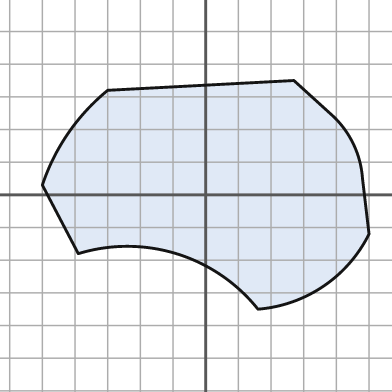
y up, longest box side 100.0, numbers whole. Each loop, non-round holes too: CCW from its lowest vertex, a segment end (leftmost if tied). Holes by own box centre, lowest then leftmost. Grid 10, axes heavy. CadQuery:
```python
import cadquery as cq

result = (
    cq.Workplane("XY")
    .moveTo(16.0, -35.0)
    .threePointArc((36.0, -28.0), (50.0, -12.0))
    .lineTo(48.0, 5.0)
    .threePointArc((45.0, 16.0), (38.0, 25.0))
    .lineTo(27.0, 35.0)
    .lineTo(-30.0, 32.0)
    .threePointArc((-42.0, 19.0), (-50.0, 3.0))
    .lineTo(-39.0, -18.0)
    .threePointArc((-9.0, -18.0), (16.0, -35.0))
    .close()
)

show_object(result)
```